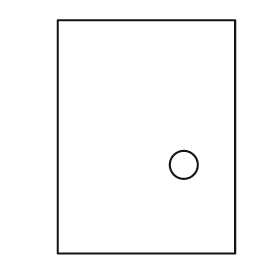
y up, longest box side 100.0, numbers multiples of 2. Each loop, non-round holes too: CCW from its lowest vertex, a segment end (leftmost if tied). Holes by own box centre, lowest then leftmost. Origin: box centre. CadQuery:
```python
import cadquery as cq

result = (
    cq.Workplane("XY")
    .moveTo(-38.0, -50.0)
    .lineTo(38.0, -50.0)
    .lineTo(38.0, 50.0)
    .lineTo(-38.0, 50.0)
    .close()
    .moveTo(16.0, -12.0)
    .circle(6.0)
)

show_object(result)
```